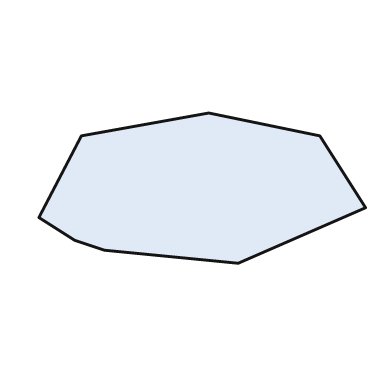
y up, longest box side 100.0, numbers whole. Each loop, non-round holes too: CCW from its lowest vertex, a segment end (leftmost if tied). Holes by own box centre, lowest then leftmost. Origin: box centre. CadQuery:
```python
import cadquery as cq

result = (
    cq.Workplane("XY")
    .moveTo(11.0, -23.0)
    .lineTo(50.0, -6.0)
    .lineTo(36.0, 16.0)
    .lineTo(2.0, 23.0)
    .lineTo(-37.0, 16.0)
    .lineTo(-50.0, -9.0)
    .lineTo(-39.0, -16.0)
    .lineTo(-30.0, -19.0)
    .close()
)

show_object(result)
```